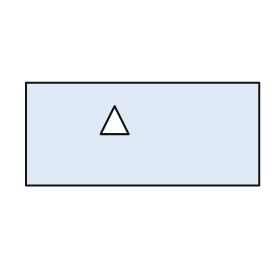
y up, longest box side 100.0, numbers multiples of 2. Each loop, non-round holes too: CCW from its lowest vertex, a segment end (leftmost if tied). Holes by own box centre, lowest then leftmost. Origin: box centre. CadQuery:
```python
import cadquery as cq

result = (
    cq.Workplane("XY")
    .moveTo(-50.0, -22.0)
    .lineTo(50.0, -22.0)
    .lineTo(50.0, 22.0)
    .lineTo(-50.0, 22.0)
    .close()
    .moveTo(-18.0, 0.0)
    .lineTo(-6.0, 0.0)
    .lineTo(-12.0, 12.0)
    .close()
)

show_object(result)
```